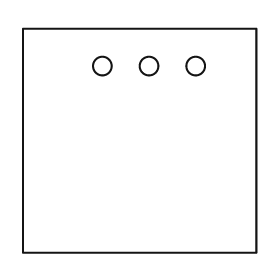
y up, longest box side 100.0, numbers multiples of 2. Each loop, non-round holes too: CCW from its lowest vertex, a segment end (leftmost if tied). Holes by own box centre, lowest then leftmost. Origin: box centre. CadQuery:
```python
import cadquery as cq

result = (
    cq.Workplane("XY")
    .moveTo(-50.0, -48.0)
    .lineTo(50.0, -48.0)
    .lineTo(50.0, 48.0)
    .lineTo(-50.0, 48.0)
    .close()
    .moveTo(-16.0, 32.0)
    .circle(4.0)
    .moveTo(4.0, 32.0)
    .circle(4.0)
    .moveTo(24.0, 32.0)
    .circle(4.0)
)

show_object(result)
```